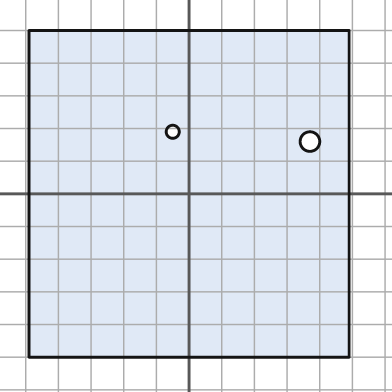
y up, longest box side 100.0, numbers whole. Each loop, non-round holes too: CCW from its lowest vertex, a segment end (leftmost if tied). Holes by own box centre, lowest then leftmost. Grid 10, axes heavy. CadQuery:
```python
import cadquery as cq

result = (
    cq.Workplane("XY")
    .moveTo(-49.0, -50.0)
    .lineTo(49.0, -50.0)
    .lineTo(49.0, 50.0)
    .lineTo(-49.0, 50.0)
    .close()
    .moveTo(37.0, 16.0)
    .circle(3.0)
    .moveTo(-5.0, 19.0)
    .circle(2.0)
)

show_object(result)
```